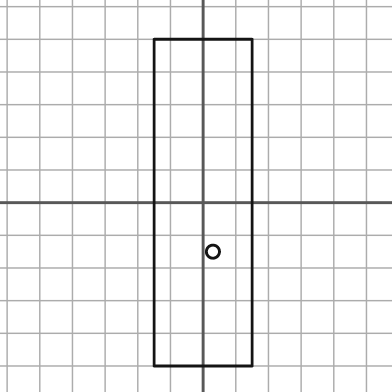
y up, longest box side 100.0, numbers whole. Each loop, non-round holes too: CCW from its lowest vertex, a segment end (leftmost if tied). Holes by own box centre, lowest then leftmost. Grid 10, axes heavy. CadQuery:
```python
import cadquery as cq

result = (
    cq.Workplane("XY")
    .moveTo(-15.0, -50.0)
    .lineTo(15.0, -50.0)
    .lineTo(15.0, 50.0)
    .lineTo(-15.0, 50.0)
    .close()
    .moveTo(3.0, -15.0)
    .circle(2.0)
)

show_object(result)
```